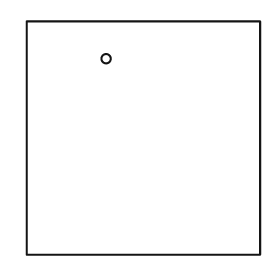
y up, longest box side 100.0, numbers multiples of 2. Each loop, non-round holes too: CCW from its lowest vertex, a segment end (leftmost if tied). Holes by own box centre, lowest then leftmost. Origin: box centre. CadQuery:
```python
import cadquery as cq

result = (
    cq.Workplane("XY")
    .moveTo(-50.0, -50.0)
    .lineTo(50.0, -50.0)
    .lineTo(50.0, 50.0)
    .lineTo(-50.0, 50.0)
    .close()
    .moveTo(-16.0, 34.0)
    .circle(2.0)
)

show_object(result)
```